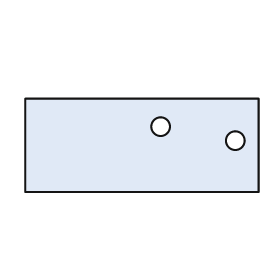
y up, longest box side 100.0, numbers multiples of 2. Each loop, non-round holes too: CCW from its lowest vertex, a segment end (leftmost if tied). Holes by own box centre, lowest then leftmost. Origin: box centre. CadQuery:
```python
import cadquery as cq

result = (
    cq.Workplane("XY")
    .moveTo(-50.0, -20.0)
    .lineTo(50.0, -20.0)
    .lineTo(50.0, 20.0)
    .lineTo(-50.0, 20.0)
    .close()
    .moveTo(40.0, 2.0)
    .circle(4.0)
    .moveTo(8.0, 8.0)
    .circle(4.0)
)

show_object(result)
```